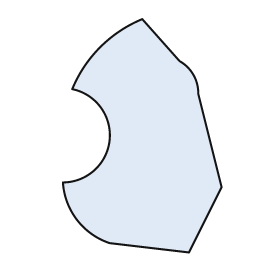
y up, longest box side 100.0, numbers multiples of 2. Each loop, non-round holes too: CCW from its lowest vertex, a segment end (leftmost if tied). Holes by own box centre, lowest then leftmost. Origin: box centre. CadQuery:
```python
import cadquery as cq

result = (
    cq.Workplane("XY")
    .moveTo(20.0, -50.0)
    .lineTo(34.0, -22.0)
    .lineTo(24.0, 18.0)
    .threePointArc((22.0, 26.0), (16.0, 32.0))
    .lineTo(0.0, 50.0)
    .threePointArc((-18.0, 38.0), (-30.0, 20.0))
    .threePointArc((-14.0, -2.0), (-34.0, -20.0))
    .threePointArc((-28.0, -36.0), (-14.0, -46.0))
    .close()
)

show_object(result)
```